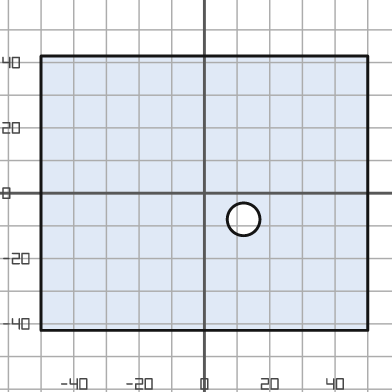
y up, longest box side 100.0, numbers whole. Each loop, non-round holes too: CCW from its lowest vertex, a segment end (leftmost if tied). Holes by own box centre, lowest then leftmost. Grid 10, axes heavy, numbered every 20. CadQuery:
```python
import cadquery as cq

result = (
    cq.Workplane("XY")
    .moveTo(-50.0, -42.0)
    .lineTo(50.0, -42.0)
    .lineTo(50.0, 42.0)
    .lineTo(-50.0, 42.0)
    .close()
    .moveTo(12.0, -8.0)
    .circle(5.0)
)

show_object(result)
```